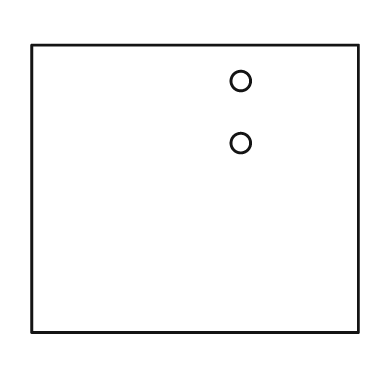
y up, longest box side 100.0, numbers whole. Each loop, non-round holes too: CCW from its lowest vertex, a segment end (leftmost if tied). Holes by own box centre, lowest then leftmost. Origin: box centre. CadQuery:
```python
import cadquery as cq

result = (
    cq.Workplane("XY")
    .moveTo(-50.0, -44.0)
    .lineTo(50.0, -44.0)
    .lineTo(50.0, 44.0)
    .lineTo(-50.0, 44.0)
    .close()
    .moveTo(14.0, 14.0)
    .circle(3.0)
    .moveTo(14.0, 33.0)
    .circle(3.0)
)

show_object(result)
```